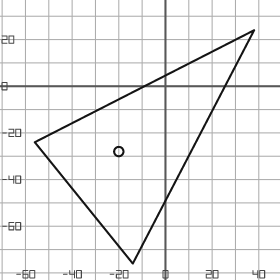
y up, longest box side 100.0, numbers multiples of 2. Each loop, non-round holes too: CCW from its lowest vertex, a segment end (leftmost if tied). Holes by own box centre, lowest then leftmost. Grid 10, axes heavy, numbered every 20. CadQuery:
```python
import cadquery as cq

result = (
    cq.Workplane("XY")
    .moveTo(-14.0, -76.0)
    .lineTo(38.0, 24.0)
    .lineTo(-56.0, -24.0)
    .close()
    .moveTo(-20.0, -28.0)
    .circle(2.0)
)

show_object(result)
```